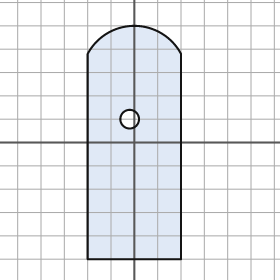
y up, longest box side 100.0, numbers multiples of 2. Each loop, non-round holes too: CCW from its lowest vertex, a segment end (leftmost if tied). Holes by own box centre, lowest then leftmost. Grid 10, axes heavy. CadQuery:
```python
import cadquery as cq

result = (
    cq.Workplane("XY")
    .moveTo(-20.0, -50.0)
    .lineTo(20.0, -50.0)
    .lineTo(20.0, 38.0)
    .threePointArc((0.0, 50.0), (-20.0, 38.0))
    .close()
    .moveTo(-2.0, 10.0)
    .circle(4.0)
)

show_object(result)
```